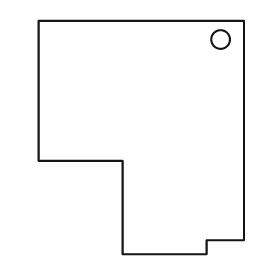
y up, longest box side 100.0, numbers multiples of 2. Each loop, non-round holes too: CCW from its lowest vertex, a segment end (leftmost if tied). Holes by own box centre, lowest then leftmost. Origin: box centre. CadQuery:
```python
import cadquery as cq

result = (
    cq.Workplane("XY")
    .moveTo(-8.0, -50.0)
    .lineTo(28.0, -50.0)
    .lineTo(28.0, -44.0)
    .lineTo(44.0, -44.0)
    .lineTo(44.0, 50.0)
    .lineTo(-44.0, 50.0)
    .lineTo(-44.0, -10.0)
    .lineTo(-8.0, -10.0)
    .close()
    .moveTo(34.0, 42.0)
    .circle(4.0)
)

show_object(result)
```